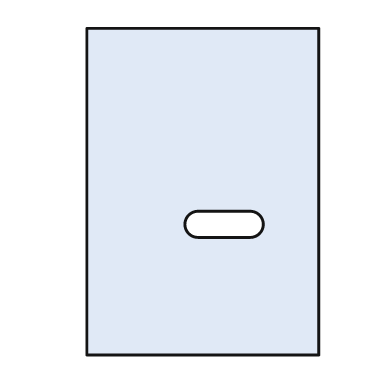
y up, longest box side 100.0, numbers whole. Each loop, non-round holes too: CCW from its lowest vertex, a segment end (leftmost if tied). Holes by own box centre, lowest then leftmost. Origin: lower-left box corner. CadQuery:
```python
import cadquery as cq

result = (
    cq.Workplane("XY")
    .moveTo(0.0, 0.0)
    .lineTo(71.0, 0.0)
    .lineTo(71.0, 100.0)
    .lineTo(0.0, 100.0)
    .close()
    .moveTo(34.0, 36.0)
    .lineTo(50.0, 36.0)
    .threePointArc((54.0, 40.0), (50.0, 44.0))
    .lineTo(34.0, 44.0)
    .threePointArc((30.0, 40.0), (34.0, 36.0))
    .close()
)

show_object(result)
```